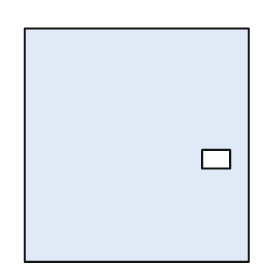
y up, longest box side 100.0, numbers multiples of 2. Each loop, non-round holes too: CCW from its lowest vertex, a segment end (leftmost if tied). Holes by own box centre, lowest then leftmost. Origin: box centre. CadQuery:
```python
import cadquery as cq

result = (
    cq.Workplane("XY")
    .moveTo(-48.0, -50.0)
    .lineTo(48.0, -50.0)
    .lineTo(48.0, 50.0)
    .lineTo(-48.0, 50.0)
    .close()
    .moveTo(28.0, -10.0)
    .lineTo(40.0, -10.0)
    .lineTo(40.0, -2.0)
    .lineTo(28.0, -2.0)
    .close()
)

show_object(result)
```